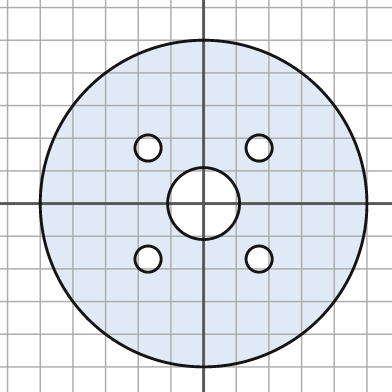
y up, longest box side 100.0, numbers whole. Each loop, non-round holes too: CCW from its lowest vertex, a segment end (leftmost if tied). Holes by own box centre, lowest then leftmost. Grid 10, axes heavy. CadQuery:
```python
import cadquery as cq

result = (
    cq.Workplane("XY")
    .moveTo(0.0, 0.0)
    .circle(50.0)
    .moveTo(-17.0, -17.0)
    .circle(4.0)
    .moveTo(17.0, -17.0)
    .circle(4.0)
    .moveTo(0.0, 0.0)
    .circle(11.0)
    .moveTo(-17.0, 17.0)
    .circle(4.0)
    .moveTo(17.0, 17.0)
    .circle(4.0)
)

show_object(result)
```